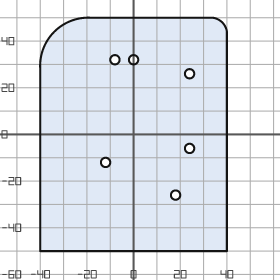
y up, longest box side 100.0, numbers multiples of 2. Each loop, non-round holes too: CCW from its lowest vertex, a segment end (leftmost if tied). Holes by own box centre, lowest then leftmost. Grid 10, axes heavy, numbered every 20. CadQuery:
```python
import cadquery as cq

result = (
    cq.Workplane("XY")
    .moveTo(-40.0, -50.0)
    .lineTo(40.0, -50.0)
    .lineTo(40.0, 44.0)
    .threePointArc((38.0, 48.0), (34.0, 50.0))
    .lineTo(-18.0, 50.0)
    .threePointArc((-34.0, 44.0), (-40.0, 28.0))
    .close()
    .moveTo(18.0, -26.0)
    .circle(2.0)
    .moveTo(-12.0, -12.0)
    .circle(2.0)
    .moveTo(24.0, -6.0)
    .circle(2.0)
    .moveTo(24.0, 26.0)
    .circle(2.0)
    .moveTo(-8.0, 32.0)
    .circle(2.0)
    .moveTo(0.0, 32.0)
    .circle(2.0)
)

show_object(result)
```